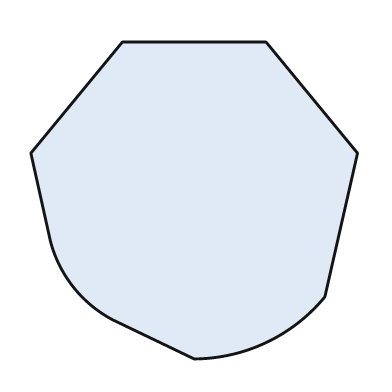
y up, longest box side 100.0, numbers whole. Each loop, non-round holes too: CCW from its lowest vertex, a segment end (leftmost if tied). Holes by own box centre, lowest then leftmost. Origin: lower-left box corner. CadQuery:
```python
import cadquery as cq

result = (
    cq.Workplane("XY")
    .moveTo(50.0, 0.0)
    .threePointArc((72.0, 5.0), (90.0, 19.0))
    .lineTo(100.0, 63.0)
    .lineTo(72.0, 97.0)
    .lineTo(28.0, 97.0)
    .lineTo(0.0, 63.0)
    .lineTo(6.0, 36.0)
    .threePointArc((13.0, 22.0), (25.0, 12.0))
    .close()
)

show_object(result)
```